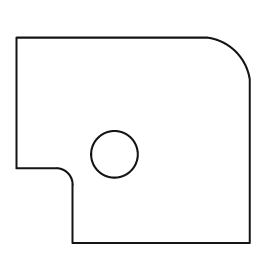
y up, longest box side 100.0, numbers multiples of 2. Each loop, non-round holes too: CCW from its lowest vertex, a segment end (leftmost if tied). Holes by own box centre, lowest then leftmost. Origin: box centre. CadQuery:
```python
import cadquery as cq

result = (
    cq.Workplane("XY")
    .moveTo(-26.0, -44.0)
    .lineTo(50.0, -44.0)
    .lineTo(50.0, 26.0)
    .threePointArc((44.0, 38.0), (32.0, 44.0))
    .lineTo(-50.0, 44.0)
    .lineTo(-50.0, -12.0)
    .lineTo(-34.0, -12.0)
    .threePointArc((-28.0, -14.0), (-26.0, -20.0))
    .close()
    .moveTo(-8.0, -6.0)
    .circle(10.0)
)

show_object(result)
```